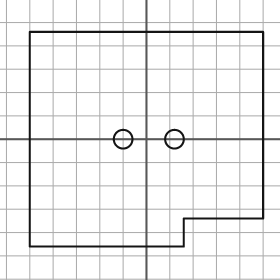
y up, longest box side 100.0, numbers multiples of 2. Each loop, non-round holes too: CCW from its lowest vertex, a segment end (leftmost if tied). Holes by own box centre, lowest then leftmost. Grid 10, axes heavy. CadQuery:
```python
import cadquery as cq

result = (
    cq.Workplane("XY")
    .moveTo(-50.0, -46.0)
    .lineTo(16.0, -46.0)
    .lineTo(16.0, -34.0)
    .lineTo(50.0, -34.0)
    .lineTo(50.0, 46.0)
    .lineTo(-50.0, 46.0)
    .close()
    .moveTo(-10.0, 0.0)
    .circle(4.0)
    .moveTo(12.0, 0.0)
    .circle(4.0)
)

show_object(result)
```